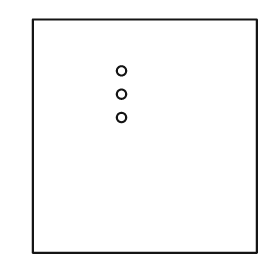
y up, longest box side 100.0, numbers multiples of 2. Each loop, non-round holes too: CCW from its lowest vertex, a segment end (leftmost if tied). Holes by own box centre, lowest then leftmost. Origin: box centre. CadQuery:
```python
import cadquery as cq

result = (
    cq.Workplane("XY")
    .moveTo(-48.0, -50.0)
    .lineTo(48.0, -50.0)
    .lineTo(48.0, 50.0)
    .lineTo(-48.0, 50.0)
    .close()
    .moveTo(-10.0, 8.0)
    .circle(2.0)
    .moveTo(-10.0, 18.0)
    .circle(2.0)
    .moveTo(-10.0, 28.0)
    .circle(2.0)
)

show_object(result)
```